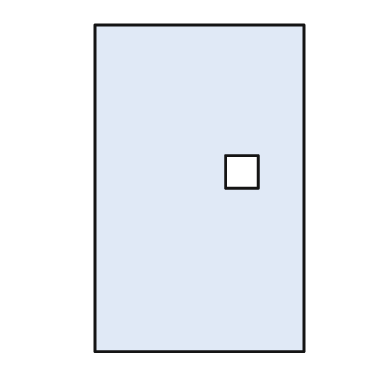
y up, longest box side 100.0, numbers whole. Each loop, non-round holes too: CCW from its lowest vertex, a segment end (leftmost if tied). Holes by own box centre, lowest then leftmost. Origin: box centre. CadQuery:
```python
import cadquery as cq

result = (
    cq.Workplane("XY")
    .moveTo(-32.0, -50.0)
    .lineTo(32.0, -50.0)
    .lineTo(32.0, 50.0)
    .lineTo(-32.0, 50.0)
    .close()
    .moveTo(8.0, 0.0)
    .lineTo(18.0, 0.0)
    .lineTo(18.0, 10.0)
    .lineTo(8.0, 10.0)
    .close()
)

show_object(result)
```